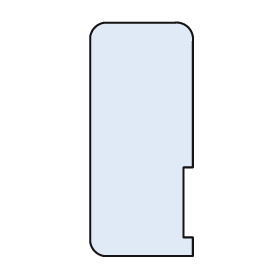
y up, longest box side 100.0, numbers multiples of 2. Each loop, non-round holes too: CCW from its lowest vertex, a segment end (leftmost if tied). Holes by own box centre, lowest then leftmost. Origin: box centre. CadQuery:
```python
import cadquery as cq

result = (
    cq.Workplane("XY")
    .moveTo(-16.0, -50.0)
    .lineTo(22.0, -50.0)
    .lineTo(22.0, -42.0)
    .lineTo(18.0, -42.0)
    .lineTo(18.0, -12.0)
    .lineTo(22.0, -12.0)
    .lineTo(22.0, 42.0)
    .threePointArc((20.0, 48.0), (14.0, 50.0))
    .lineTo(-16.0, 50.0)
    .threePointArc((-20.0, 48.0), (-22.0, 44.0))
    .lineTo(-22.0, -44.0)
    .threePointArc((-20.0, -48.0), (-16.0, -50.0))
    .close()
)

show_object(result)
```